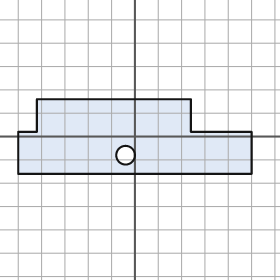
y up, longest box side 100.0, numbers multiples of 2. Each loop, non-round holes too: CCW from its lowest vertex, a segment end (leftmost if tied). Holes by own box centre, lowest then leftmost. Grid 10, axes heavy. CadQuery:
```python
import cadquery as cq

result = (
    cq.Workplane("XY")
    .moveTo(-50.0, -16.0)
    .lineTo(50.0, -16.0)
    .lineTo(50.0, 2.0)
    .lineTo(24.0, 2.0)
    .lineTo(24.0, 16.0)
    .lineTo(-42.0, 16.0)
    .lineTo(-42.0, 2.0)
    .lineTo(-50.0, 2.0)
    .close()
    .moveTo(-4.0, -8.0)
    .circle(4.0)
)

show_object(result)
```